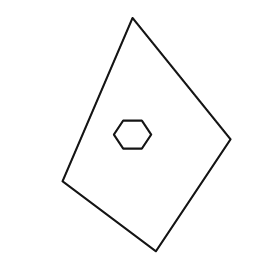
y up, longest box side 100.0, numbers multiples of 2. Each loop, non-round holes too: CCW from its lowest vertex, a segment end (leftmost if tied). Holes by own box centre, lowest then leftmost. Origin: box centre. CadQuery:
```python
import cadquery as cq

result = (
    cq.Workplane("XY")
    .moveTo(4.0, -50.0)
    .lineTo(36.0, -2.0)
    .lineTo(-6.0, 50.0)
    .lineTo(-36.0, -20.0)
    .close()
    .moveTo(-10.0, -6.0)
    .lineTo(-2.0, -6.0)
    .lineTo(2.0, 0.0)
    .lineTo(-2.0, 6.0)
    .lineTo(-10.0, 6.0)
    .lineTo(-14.0, 0.0)
    .close()
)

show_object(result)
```